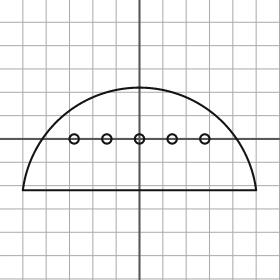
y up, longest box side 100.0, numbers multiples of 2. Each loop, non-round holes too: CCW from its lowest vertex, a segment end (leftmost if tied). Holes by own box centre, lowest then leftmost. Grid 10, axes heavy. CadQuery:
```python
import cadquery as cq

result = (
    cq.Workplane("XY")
    .moveTo(-50.0, -22.0)
    .lineTo(50.0, -22.0)
    .threePointArc((0.0, 22.0), (-50.0, -22.0))
    .close()
    .moveTo(-28.0, 0.0)
    .circle(2.0)
    .moveTo(-14.0, 0.0)
    .circle(2.0)
    .moveTo(0.0, 0.0)
    .circle(2.0)
    .moveTo(14.0, 0.0)
    .circle(2.0)
    .moveTo(28.0, 0.0)
    .circle(2.0)
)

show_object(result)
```